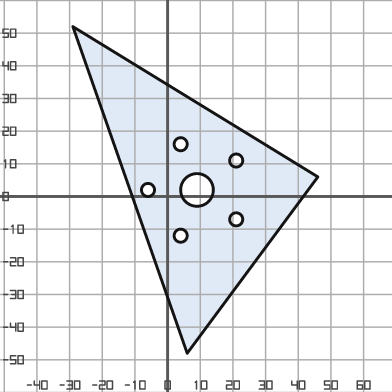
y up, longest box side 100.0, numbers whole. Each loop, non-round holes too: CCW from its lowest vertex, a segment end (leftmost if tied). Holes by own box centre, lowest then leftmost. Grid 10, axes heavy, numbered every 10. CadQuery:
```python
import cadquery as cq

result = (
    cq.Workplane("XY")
    .moveTo(6.0, -48.0)
    .lineTo(46.0, 6.0)
    .lineTo(-29.0, 52.0)
    .close()
    .moveTo(4.0, -12.0)
    .circle(2.0)
    .moveTo(21.0, -7.0)
    .circle(2.0)
    .moveTo(-6.0, 2.0)
    .circle(2.0)
    .moveTo(9.0, 2.0)
    .circle(5.0)
    .moveTo(21.0, 11.0)
    .circle(2.0)
    .moveTo(4.0, 16.0)
    .circle(2.0)
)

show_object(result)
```